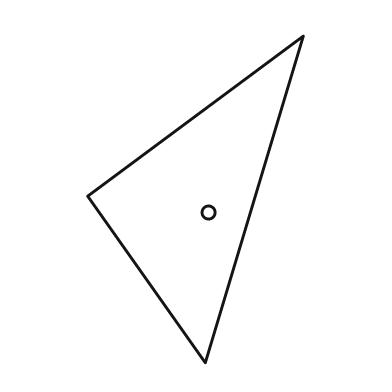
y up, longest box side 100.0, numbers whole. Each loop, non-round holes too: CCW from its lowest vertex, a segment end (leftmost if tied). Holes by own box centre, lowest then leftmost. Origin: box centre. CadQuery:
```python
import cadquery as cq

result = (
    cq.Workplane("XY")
    .moveTo(3.0, -50.0)
    .lineTo(33.0, 50.0)
    .lineTo(-33.0, 1.0)
    .close()
    .moveTo(4.0, -4.0)
    .circle(2.0)
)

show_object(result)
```